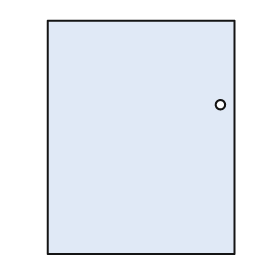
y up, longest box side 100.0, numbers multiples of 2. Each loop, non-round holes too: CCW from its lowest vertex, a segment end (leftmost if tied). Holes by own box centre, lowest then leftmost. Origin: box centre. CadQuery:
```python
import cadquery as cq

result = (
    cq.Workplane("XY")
    .moveTo(-40.0, -50.0)
    .lineTo(40.0, -50.0)
    .lineTo(40.0, 50.0)
    .lineTo(-40.0, 50.0)
    .close()
    .moveTo(34.0, 14.0)
    .circle(2.0)
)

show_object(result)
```